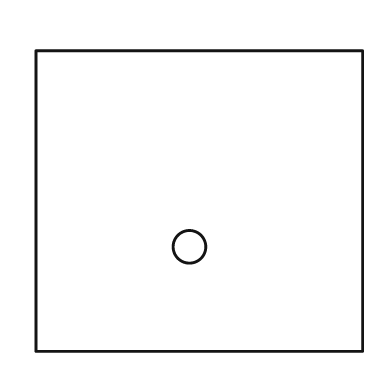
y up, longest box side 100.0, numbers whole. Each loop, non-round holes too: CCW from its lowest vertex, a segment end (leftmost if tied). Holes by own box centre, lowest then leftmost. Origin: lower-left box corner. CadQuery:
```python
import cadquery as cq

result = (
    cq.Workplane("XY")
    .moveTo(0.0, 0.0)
    .lineTo(100.0, 0.0)
    .lineTo(100.0, 92.0)
    .lineTo(0.0, 92.0)
    .close()
    .moveTo(47.0, 32.0)
    .circle(5.0)
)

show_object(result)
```